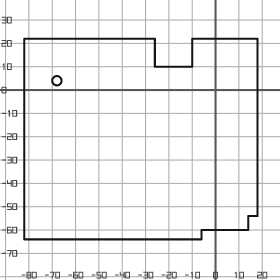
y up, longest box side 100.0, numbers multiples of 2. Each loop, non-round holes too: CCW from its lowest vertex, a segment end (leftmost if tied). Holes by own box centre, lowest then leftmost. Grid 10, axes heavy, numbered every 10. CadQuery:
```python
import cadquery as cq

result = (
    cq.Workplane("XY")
    .moveTo(-82.0, -64.0)
    .lineTo(-6.0, -64.0)
    .lineTo(-6.0, -60.0)
    .lineTo(14.0, -60.0)
    .lineTo(14.0, -54.0)
    .lineTo(18.0, -54.0)
    .lineTo(18.0, 22.0)
    .lineTo(-10.0, 22.0)
    .lineTo(-10.0, 10.0)
    .lineTo(-26.0, 10.0)
    .lineTo(-26.0, 22.0)
    .lineTo(-82.0, 22.0)
    .close()
    .moveTo(-68.0, 4.0)
    .circle(2.0)
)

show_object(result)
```